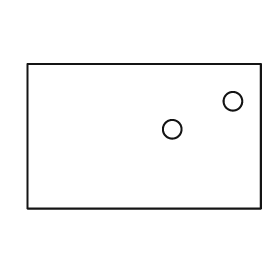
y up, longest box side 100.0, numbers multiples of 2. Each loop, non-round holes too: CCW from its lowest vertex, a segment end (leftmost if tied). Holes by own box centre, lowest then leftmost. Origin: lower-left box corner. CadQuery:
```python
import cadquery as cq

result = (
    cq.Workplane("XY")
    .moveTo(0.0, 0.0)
    .lineTo(100.0, 0.0)
    .lineTo(100.0, 62.0)
    .lineTo(0.0, 62.0)
    .close()
    .moveTo(62.0, 34.0)
    .circle(4.0)
    .moveTo(88.0, 46.0)
    .circle(4.0)
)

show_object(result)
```